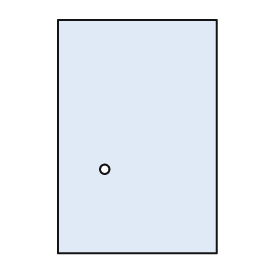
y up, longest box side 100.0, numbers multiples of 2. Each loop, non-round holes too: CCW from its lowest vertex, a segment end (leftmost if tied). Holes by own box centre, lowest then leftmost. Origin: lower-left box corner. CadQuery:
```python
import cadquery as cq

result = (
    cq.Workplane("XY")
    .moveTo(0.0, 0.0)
    .lineTo(68.0, 0.0)
    .lineTo(68.0, 100.0)
    .lineTo(0.0, 100.0)
    .close()
    .moveTo(20.0, 36.0)
    .circle(2.0)
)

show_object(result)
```